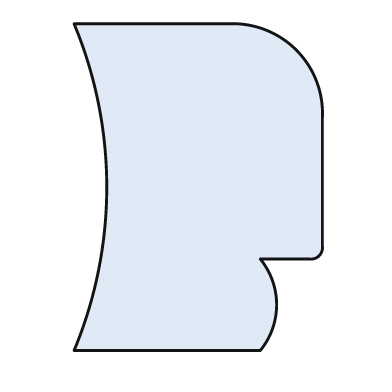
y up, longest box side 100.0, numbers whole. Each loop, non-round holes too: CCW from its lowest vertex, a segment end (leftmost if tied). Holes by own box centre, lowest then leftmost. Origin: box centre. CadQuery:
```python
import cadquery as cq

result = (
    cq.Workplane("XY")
    .moveTo(-38.0, -50.0)
    .lineTo(19.0, -50.0)
    .threePointArc((24.0, -36.0), (19.0, -22.0))
    .lineTo(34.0, -22.0)
    .threePointArc((37.0, -21.0), (38.0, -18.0))
    .lineTo(38.0, 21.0)
    .threePointArc((30.0, 42.0), (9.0, 50.0))
    .lineTo(-38.0, 50.0)
    .threePointArc((-28.0, 0.0), (-38.0, -50.0))
    .close()
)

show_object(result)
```